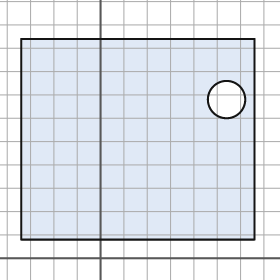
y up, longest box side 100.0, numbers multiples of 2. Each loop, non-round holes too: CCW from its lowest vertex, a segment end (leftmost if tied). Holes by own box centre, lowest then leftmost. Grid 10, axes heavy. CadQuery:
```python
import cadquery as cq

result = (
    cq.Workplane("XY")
    .moveTo(-34.0, 8.0)
    .lineTo(66.0, 8.0)
    .lineTo(66.0, 94.0)
    .lineTo(-34.0, 94.0)
    .close()
    .moveTo(54.0, 68.0)
    .circle(8.0)
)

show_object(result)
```